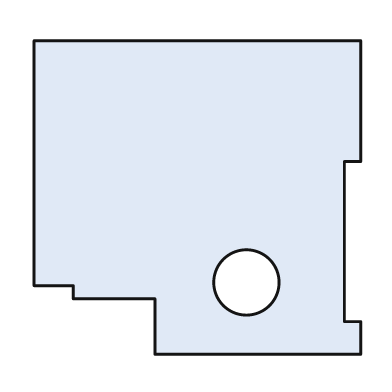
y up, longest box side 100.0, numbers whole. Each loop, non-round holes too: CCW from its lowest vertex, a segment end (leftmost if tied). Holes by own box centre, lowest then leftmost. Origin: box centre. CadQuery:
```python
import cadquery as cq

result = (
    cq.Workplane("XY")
    .moveTo(-13.0, -48.0)
    .lineTo(50.0, -48.0)
    .lineTo(50.0, -38.0)
    .lineTo(45.0, -38.0)
    .lineTo(45.0, 11.0)
    .lineTo(50.0, 11.0)
    .lineTo(50.0, 48.0)
    .lineTo(-50.0, 48.0)
    .lineTo(-50.0, -27.0)
    .lineTo(-38.0, -27.0)
    .lineTo(-38.0, -31.0)
    .lineTo(-13.0, -31.0)
    .close()
    .moveTo(15.0, -26.0)
    .circle(10.0)
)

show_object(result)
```